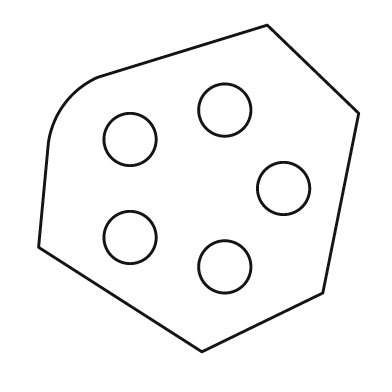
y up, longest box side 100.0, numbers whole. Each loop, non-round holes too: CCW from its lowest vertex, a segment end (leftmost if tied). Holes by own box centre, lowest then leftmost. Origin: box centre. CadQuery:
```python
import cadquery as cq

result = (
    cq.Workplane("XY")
    .moveTo(1.0, -50.0)
    .lineTo(38.0, -32.0)
    .lineTo(49.0, 23.0)
    .lineTo(21.0, 50.0)
    .lineTo(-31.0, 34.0)
    .threePointArc((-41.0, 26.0), (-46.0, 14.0))
    .lineTo(-49.0, -18.0)
    .close()
    .moveTo(8.0, -24.0)
    .circle(8.0)
    .moveTo(-21.0, -15.0)
    .circle(8.0)
    .moveTo(26.0, 0.0)
    .circle(8.0)
    .moveTo(-21.0, 15.0)
    .circle(8.0)
    .moveTo(8.0, 24.0)
    .circle(8.0)
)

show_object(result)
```